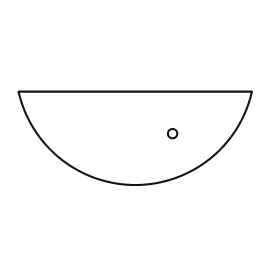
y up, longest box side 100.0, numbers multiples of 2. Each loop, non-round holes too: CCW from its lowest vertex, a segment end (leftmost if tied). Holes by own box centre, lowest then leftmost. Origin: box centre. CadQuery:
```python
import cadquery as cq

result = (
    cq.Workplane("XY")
    .moveTo(-50.0, 20.0)
    .threePointArc((0.0, -20.0), (50.0, 20.0))
    .close()
    .moveTo(16.0, 2.0)
    .circle(2.0)
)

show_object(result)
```